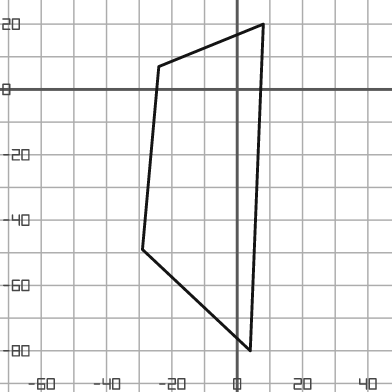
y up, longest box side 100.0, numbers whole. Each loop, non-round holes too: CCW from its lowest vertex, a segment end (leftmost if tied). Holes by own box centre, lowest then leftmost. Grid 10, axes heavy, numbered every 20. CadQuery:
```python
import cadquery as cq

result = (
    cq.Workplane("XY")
    .moveTo(4.0, -80.0)
    .lineTo(8.0, 20.0)
    .lineTo(-24.0, 7.0)
    .lineTo(-29.0, -49.0)
    .close()
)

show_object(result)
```